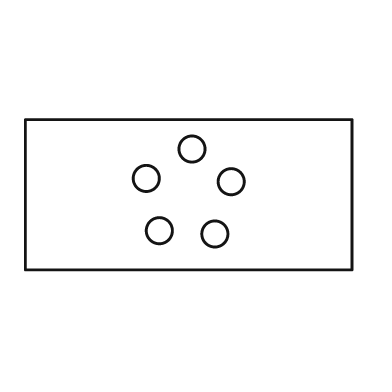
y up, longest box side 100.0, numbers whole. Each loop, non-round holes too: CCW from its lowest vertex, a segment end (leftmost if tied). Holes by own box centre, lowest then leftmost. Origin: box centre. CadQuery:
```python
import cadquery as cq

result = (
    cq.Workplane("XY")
    .moveTo(-50.0, -23.0)
    .lineTo(50.0, -23.0)
    .lineTo(50.0, 23.0)
    .lineTo(-50.0, 23.0)
    .close()
    .moveTo(8.0, -12.0)
    .circle(4.0)
    .moveTo(-9.0, -11.0)
    .circle(4.0)
    .moveTo(13.0, 4.0)
    .circle(4.0)
    .moveTo(-13.0, 5.0)
    .circle(4.0)
    .moveTo(1.0, 14.0)
    .circle(4.0)
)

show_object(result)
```